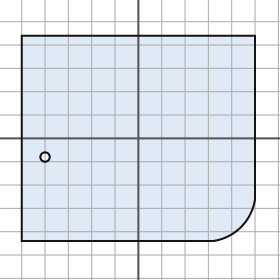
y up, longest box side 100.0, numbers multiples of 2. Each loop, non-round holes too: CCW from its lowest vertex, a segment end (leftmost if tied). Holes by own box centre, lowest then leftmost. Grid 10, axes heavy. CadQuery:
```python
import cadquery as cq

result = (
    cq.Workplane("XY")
    .moveTo(-50.0, -44.0)
    .lineTo(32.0, -44.0)
    .threePointArc((44.0, -38.0), (50.0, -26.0))
    .lineTo(50.0, 44.0)
    .lineTo(-50.0, 44.0)
    .close()
    .moveTo(-40.0, -8.0)
    .circle(2.0)
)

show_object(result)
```